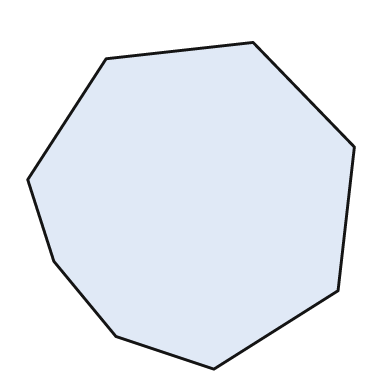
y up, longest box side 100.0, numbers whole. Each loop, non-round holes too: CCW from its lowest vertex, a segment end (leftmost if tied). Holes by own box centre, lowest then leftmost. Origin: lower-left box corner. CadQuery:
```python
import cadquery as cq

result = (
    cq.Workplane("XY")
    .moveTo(57.0, 0.0)
    .lineTo(95.0, 24.0)
    .lineTo(100.0, 68.0)
    .lineTo(69.0, 100.0)
    .lineTo(24.0, 95.0)
    .lineTo(0.0, 58.0)
    .lineTo(8.0, 33.0)
    .lineTo(27.0, 10.0)
    .close()
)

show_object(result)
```